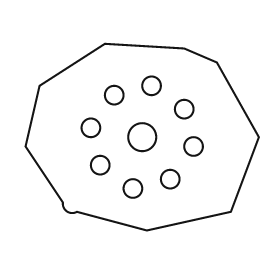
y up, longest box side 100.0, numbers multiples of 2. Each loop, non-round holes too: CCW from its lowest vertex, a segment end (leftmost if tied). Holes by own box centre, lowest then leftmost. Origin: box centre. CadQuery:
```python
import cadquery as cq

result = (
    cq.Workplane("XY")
    .moveTo(2.0, -40.0)
    .lineTo(38.0, -32.0)
    .lineTo(50.0, 0.0)
    .lineTo(32.0, 32.0)
    .lineTo(18.0, 38.0)
    .lineTo(-16.0, 40.0)
    .lineTo(-44.0, 22.0)
    .lineTo(-50.0, -4.0)
    .lineTo(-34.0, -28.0)
    .threePointArc((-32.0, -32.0), (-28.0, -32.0))
    .close()
    .moveTo(-4.0, -22.0)
    .circle(4.0)
    .moveTo(12.0, -18.0)
    .circle(4.0)
    .moveTo(-18.0, -12.0)
    .circle(4.0)
    .moveTo(22.0, -4.0)
    .circle(4.0)
    .moveTo(0.0, 0.0)
    .circle(6.0)
    .moveTo(-22.0, 4.0)
    .circle(4.0)
    .moveTo(18.0, 12.0)
    .circle(4.0)
    .moveTo(-12.0, 18.0)
    .circle(4.0)
    .moveTo(4.0, 22.0)
    .circle(4.0)
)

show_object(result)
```